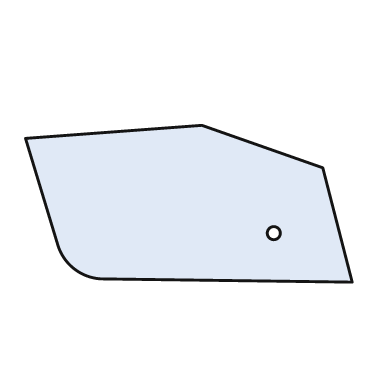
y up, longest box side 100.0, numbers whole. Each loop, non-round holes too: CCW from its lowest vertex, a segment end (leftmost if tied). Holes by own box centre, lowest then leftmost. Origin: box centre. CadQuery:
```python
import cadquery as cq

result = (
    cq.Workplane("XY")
    .moveTo(50.0, -24.0)
    .lineTo(41.0, 11.0)
    .lineTo(4.0, 24.0)
    .lineTo(-50.0, 20.0)
    .lineTo(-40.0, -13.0)
    .threePointArc((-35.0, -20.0), (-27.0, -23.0))
    .close()
    .moveTo(26.0, -9.0)
    .circle(2.0)
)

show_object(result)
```